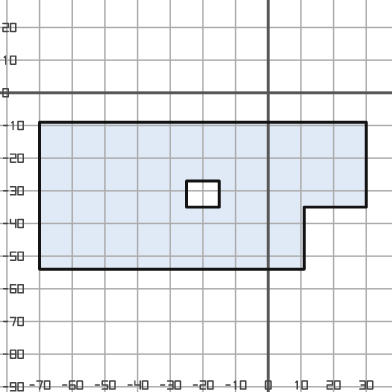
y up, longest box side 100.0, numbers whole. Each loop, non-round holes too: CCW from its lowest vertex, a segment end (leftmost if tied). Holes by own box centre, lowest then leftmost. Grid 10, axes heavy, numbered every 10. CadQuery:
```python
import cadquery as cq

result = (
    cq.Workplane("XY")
    .moveTo(-70.0, -54.0)
    .lineTo(11.0, -54.0)
    .lineTo(11.0, -35.0)
    .lineTo(30.0, -35.0)
    .lineTo(30.0, -9.0)
    .lineTo(-70.0, -9.0)
    .close()
    .moveTo(-25.0, -35.0)
    .lineTo(-15.0, -35.0)
    .lineTo(-15.0, -27.0)
    .lineTo(-25.0, -27.0)
    .close()
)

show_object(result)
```